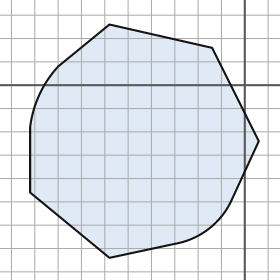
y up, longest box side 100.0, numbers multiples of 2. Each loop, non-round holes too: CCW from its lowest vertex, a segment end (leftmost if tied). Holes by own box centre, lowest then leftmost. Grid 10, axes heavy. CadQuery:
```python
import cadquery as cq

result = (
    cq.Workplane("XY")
    .moveTo(-58.0, -74.0)
    .lineTo(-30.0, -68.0)
    .threePointArc((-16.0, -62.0), (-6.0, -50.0))
    .lineTo(6.0, -24.0)
    .lineTo(-14.0, 16.0)
    .lineTo(-58.0, 26.0)
    .lineTo(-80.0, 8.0)
    .threePointArc((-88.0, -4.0), (-92.0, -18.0))
    .lineTo(-92.0, -46.0)
    .close()
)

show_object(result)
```